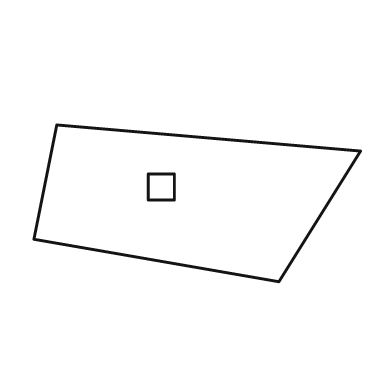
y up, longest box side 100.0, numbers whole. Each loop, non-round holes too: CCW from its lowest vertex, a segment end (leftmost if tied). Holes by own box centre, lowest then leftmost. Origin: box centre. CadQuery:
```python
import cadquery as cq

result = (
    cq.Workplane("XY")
    .moveTo(25.0, -24.0)
    .lineTo(50.0, 16.0)
    .lineTo(-43.0, 24.0)
    .lineTo(-50.0, -11.0)
    .close()
    .moveTo(-15.0, 1.0)
    .lineTo(-7.0, 1.0)
    .lineTo(-7.0, 9.0)
    .lineTo(-15.0, 9.0)
    .close()
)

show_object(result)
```